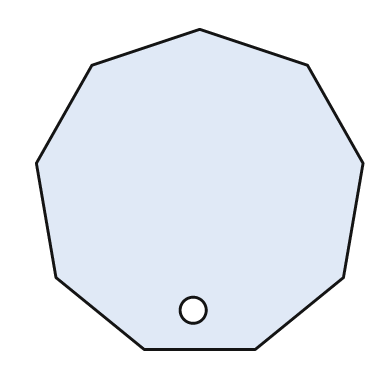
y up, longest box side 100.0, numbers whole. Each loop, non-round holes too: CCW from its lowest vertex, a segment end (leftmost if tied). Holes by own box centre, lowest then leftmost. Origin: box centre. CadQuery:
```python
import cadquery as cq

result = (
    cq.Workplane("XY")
    .moveTo(-17.0, -49.0)
    .lineTo(17.0, -49.0)
    .lineTo(44.0, -27.0)
    .lineTo(50.0, 8.0)
    .lineTo(33.0, 38.0)
    .lineTo(0.0, 49.0)
    .lineTo(-33.0, 38.0)
    .lineTo(-50.0, 8.0)
    .lineTo(-44.0, -27.0)
    .close()
    .moveTo(-2.0, -37.0)
    .circle(4.0)
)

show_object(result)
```